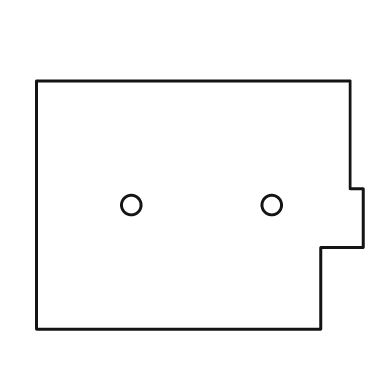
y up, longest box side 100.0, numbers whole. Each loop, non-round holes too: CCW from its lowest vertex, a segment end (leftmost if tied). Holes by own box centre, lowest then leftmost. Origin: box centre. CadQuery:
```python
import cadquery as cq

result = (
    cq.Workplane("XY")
    .moveTo(-50.0, -38.0)
    .lineTo(37.0, -38.0)
    .lineTo(37.0, -13.0)
    .lineTo(50.0, -13.0)
    .lineTo(50.0, 5.0)
    .lineTo(46.0, 5.0)
    .lineTo(46.0, 38.0)
    .lineTo(-50.0, 38.0)
    .close()
    .moveTo(-21.0, 0.0)
    .circle(3.0)
    .moveTo(22.0, 0.0)
    .circle(3.0)
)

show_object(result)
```